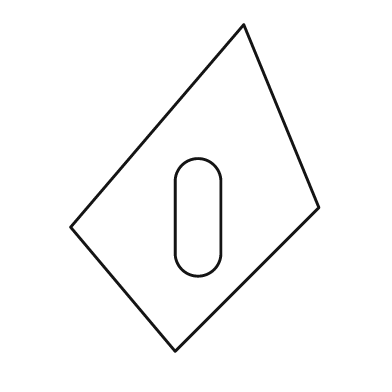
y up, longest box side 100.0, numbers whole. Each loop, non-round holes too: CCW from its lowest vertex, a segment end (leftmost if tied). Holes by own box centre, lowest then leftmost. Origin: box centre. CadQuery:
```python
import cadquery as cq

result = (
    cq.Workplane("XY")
    .moveTo(-6.0, -50.0)
    .lineTo(38.0, -6.0)
    .lineTo(15.0, 50.0)
    .lineTo(-38.0, -12.0)
    .close()
    .moveTo(-6.0, -20.0)
    .threePointArc((1.0, -27.0), (8.0, -20.0))
    .lineTo(8.0, 2.0)
    .threePointArc((1.0, 9.0), (-6.0, 2.0))
    .close()
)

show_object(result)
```